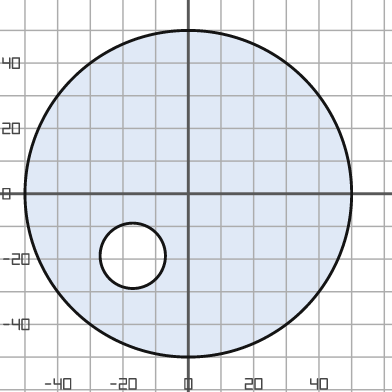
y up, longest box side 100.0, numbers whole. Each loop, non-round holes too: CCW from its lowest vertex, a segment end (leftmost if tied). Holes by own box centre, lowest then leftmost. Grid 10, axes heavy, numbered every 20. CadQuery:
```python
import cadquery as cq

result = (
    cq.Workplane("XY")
    .moveTo(0.0, 0.0)
    .circle(50.0)
    .moveTo(-17.0, -19.0)
    .circle(10.0)
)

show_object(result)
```